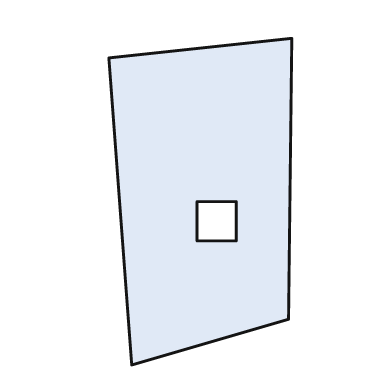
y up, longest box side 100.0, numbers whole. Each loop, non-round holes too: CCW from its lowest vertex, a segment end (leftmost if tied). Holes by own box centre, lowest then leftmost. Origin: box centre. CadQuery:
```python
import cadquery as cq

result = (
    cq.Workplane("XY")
    .moveTo(-21.0, -50.0)
    .lineTo(27.0, -36.0)
    .lineTo(28.0, 50.0)
    .lineTo(-28.0, 44.0)
    .close()
    .moveTo(-1.0, -12.0)
    .lineTo(11.0, -12.0)
    .lineTo(11.0, 0.0)
    .lineTo(-1.0, 0.0)
    .close()
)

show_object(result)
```